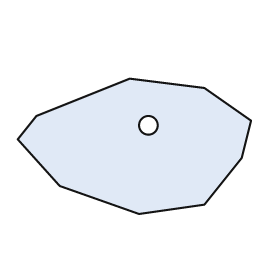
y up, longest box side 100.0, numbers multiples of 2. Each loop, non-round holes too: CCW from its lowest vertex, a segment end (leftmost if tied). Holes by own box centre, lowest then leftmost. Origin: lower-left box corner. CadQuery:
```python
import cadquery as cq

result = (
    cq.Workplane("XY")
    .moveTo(52.0, 0.0)
    .lineTo(80.0, 4.0)
    .lineTo(96.0, 24.0)
    .lineTo(100.0, 40.0)
    .lineTo(80.0, 54.0)
    .lineTo(48.0, 58.0)
    .lineTo(8.0, 42.0)
    .lineTo(0.0, 32.0)
    .lineTo(18.0, 12.0)
    .close()
    .moveTo(56.0, 38.0)
    .circle(4.0)
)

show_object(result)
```